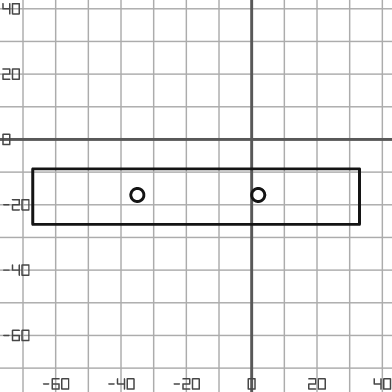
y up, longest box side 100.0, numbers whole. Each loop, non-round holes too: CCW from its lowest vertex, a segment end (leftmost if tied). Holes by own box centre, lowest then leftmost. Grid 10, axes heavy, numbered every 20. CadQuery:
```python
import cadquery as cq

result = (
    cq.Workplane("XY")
    .moveTo(-67.0, -26.0)
    .lineTo(33.0, -26.0)
    .lineTo(33.0, -9.0)
    .lineTo(-67.0, -9.0)
    .close()
    .moveTo(-35.0, -17.0)
    .circle(2.0)
    .moveTo(2.0, -17.0)
    .circle(2.0)
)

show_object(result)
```